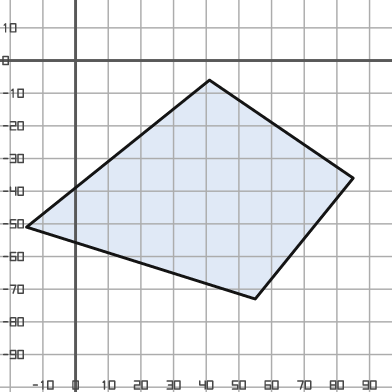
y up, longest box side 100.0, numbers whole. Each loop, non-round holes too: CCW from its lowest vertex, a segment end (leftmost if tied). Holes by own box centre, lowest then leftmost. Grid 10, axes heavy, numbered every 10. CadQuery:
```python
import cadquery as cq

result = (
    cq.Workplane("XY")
    .moveTo(55.0, -73.0)
    .lineTo(85.0, -36.0)
    .lineTo(41.0, -6.0)
    .lineTo(-15.0, -51.0)
    .close()
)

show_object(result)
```